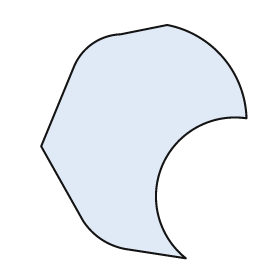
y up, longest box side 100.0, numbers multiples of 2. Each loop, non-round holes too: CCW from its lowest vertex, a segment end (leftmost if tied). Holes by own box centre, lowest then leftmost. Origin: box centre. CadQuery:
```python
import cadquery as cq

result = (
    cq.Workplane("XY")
    .moveTo(18.0, -50.0)
    .threePointArc((8.0, -10.0), (44.0, 10.0))
    .threePointArc((34.0, 36.0), (10.0, 50.0))
    .lineTo(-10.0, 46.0)
    .threePointArc((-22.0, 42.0), (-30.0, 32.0))
    .lineTo(-44.0, -2.0)
    .lineTo(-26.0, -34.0)
    .threePointArc((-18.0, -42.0), (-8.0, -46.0))
    .close()
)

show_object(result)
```